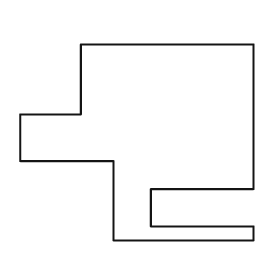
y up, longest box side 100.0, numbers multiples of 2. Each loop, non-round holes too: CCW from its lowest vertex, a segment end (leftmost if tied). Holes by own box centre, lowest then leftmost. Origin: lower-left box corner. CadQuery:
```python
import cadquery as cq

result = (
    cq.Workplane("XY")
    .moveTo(40.0, 0.0)
    .lineTo(100.0, 0.0)
    .lineTo(100.0, 6.0)
    .lineTo(56.0, 6.0)
    .lineTo(56.0, 22.0)
    .lineTo(100.0, 22.0)
    .lineTo(100.0, 84.0)
    .lineTo(26.0, 84.0)
    .lineTo(26.0, 54.0)
    .lineTo(0.0, 54.0)
    .lineTo(0.0, 34.0)
    .lineTo(40.0, 34.0)
    .close()
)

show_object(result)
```